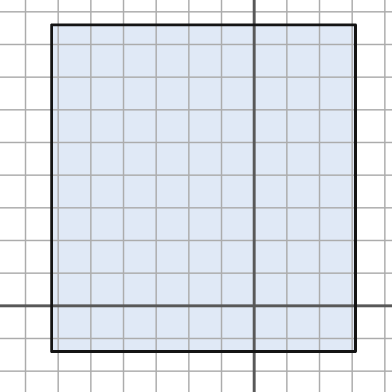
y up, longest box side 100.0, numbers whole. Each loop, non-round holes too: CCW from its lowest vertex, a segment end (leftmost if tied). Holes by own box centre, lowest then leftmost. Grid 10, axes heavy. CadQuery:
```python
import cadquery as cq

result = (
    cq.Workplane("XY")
    .moveTo(-62.0, -14.0)
    .lineTo(31.0, -14.0)
    .lineTo(31.0, 86.0)
    .lineTo(-62.0, 86.0)
    .close()
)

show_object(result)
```